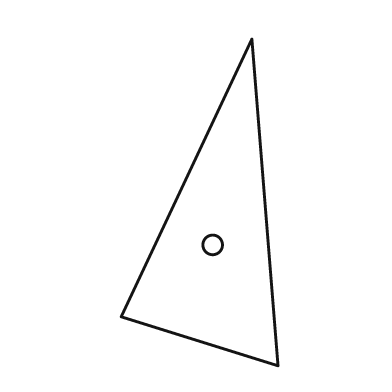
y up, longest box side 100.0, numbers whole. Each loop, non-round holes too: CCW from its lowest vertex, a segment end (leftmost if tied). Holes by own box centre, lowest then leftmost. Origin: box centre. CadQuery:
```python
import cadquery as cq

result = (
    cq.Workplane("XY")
    .moveTo(24.0, -50.0)
    .lineTo(16.0, 50.0)
    .lineTo(-24.0, -35.0)
    .close()
    .moveTo(4.0, -13.0)
    .circle(3.0)
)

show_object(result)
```